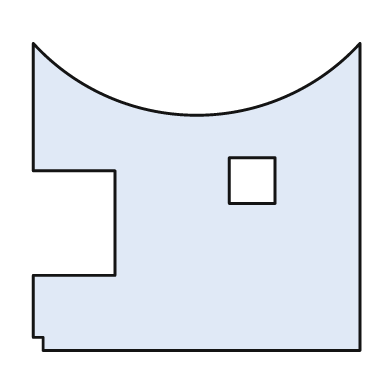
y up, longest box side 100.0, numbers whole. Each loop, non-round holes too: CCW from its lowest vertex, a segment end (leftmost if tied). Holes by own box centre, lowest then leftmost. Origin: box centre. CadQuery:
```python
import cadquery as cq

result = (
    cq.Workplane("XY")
    .moveTo(-47.0, -47.0)
    .lineTo(50.0, -47.0)
    .lineTo(50.0, 47.0)
    .threePointArc((0.0, 25.0), (-50.0, 47.0))
    .lineTo(-50.0, 8.0)
    .lineTo(-25.0, 8.0)
    .lineTo(-25.0, -24.0)
    .lineTo(-50.0, -24.0)
    .lineTo(-50.0, -43.0)
    .lineTo(-47.0, -43.0)
    .close()
    .moveTo(10.0, -2.0)
    .lineTo(24.0, -2.0)
    .lineTo(24.0, 12.0)
    .lineTo(10.0, 12.0)
    .close()
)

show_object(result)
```